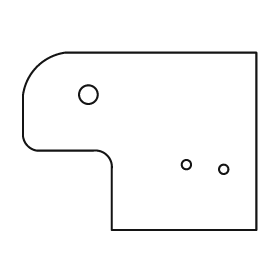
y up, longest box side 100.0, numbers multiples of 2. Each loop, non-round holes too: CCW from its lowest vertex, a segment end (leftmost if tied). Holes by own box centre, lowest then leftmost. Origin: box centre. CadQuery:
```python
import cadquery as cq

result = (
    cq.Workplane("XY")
    .moveTo(-12.0, -38.0)
    .lineTo(50.0, -38.0)
    .lineTo(50.0, 38.0)
    .lineTo(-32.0, 38.0)
    .threePointArc((-44.0, 32.0), (-50.0, 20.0))
    .lineTo(-50.0, 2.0)
    .threePointArc((-48.0, -2.0), (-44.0, -4.0))
    .lineTo(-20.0, -4.0)
    .threePointArc((-14.0, -6.0), (-12.0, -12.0))
    .close()
    .moveTo(36.0, -12.0)
    .circle(2.0)
    .moveTo(20.0, -10.0)
    .circle(2.0)
    .moveTo(-22.0, 20.0)
    .circle(4.0)
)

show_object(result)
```